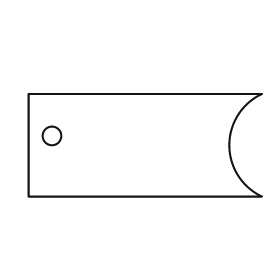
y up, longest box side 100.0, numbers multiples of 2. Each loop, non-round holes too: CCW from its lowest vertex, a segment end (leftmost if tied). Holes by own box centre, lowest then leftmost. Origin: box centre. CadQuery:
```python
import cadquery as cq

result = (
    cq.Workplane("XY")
    .moveTo(-50.0, -22.0)
    .lineTo(50.0, -22.0)
    .threePointArc((36.0, 0.0), (50.0, 22.0))
    .lineTo(-50.0, 22.0)
    .close()
    .moveTo(-40.0, 4.0)
    .circle(4.0)
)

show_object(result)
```